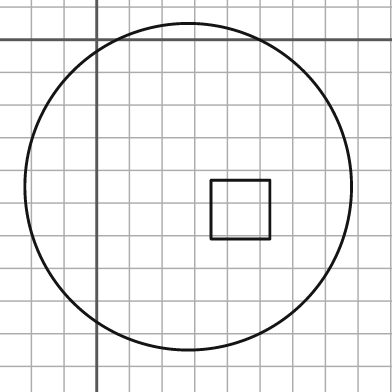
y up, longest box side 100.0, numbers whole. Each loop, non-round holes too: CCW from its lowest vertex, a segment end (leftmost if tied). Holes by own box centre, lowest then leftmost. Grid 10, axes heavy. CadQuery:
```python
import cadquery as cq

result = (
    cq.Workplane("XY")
    .moveTo(28.0, -45.0)
    .circle(50.0)
    .moveTo(35.0, -61.0)
    .lineTo(53.0, -61.0)
    .lineTo(53.0, -43.0)
    .lineTo(35.0, -43.0)
    .close()
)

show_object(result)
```